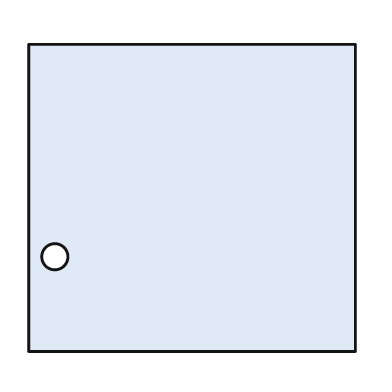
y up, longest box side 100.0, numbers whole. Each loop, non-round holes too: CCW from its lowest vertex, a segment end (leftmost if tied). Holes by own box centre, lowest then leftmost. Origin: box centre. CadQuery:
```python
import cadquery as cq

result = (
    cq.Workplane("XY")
    .moveTo(-50.0, -47.0)
    .lineTo(50.0, -47.0)
    .lineTo(50.0, 47.0)
    .lineTo(-50.0, 47.0)
    .close()
    .moveTo(-42.0, -18.0)
    .circle(4.0)
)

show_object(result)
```